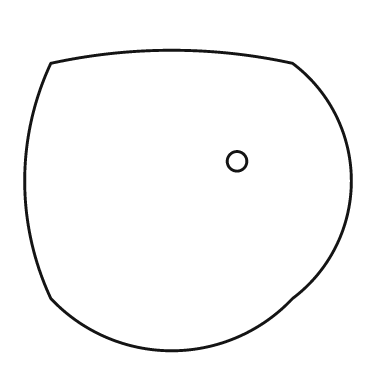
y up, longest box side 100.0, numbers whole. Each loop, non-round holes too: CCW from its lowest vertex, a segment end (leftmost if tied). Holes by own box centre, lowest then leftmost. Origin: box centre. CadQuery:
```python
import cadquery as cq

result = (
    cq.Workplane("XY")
    .moveTo(-42.0, -30.0)
    .threePointArc((-5.0, -46.0), (32.0, -30.0))
    .threePointArc((50.0, 6.0), (32.0, 42.0))
    .threePointArc((-5.0, 46.0), (-42.0, 42.0))
    .threePointArc((-50.0, 6.0), (-42.0, -30.0))
    .close()
    .moveTo(15.0, 12.0)
    .circle(3.0)
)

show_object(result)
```